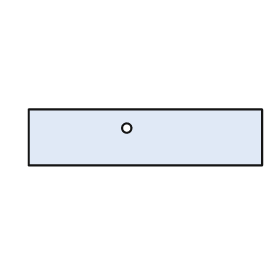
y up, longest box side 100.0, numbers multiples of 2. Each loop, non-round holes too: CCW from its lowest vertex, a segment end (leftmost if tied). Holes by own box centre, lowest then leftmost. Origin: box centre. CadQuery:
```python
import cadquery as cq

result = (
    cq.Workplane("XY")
    .moveTo(-50.0, -12.0)
    .lineTo(50.0, -12.0)
    .lineTo(50.0, 12.0)
    .lineTo(-50.0, 12.0)
    .close()
    .moveTo(-8.0, 4.0)
    .circle(2.0)
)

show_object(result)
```